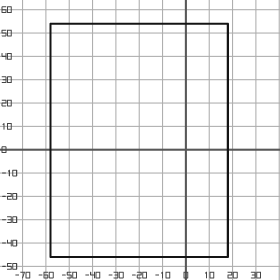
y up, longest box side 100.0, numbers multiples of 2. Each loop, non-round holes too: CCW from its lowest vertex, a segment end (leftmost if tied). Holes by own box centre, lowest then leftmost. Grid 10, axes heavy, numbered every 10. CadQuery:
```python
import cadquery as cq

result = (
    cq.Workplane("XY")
    .moveTo(-58.0, -46.0)
    .lineTo(18.0, -46.0)
    .lineTo(18.0, 54.0)
    .lineTo(-58.0, 54.0)
    .close()
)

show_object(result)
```